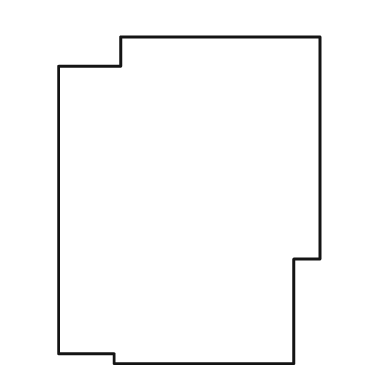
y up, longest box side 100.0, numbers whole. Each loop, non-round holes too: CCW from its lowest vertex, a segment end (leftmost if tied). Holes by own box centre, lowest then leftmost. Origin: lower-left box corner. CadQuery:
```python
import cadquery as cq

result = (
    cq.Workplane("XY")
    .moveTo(17.0, 0.0)
    .lineTo(72.0, 0.0)
    .lineTo(72.0, 32.0)
    .lineTo(80.0, 32.0)
    .lineTo(80.0, 100.0)
    .lineTo(19.0, 100.0)
    .lineTo(19.0, 91.0)
    .lineTo(0.0, 91.0)
    .lineTo(0.0, 3.0)
    .lineTo(17.0, 3.0)
    .close()
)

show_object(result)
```